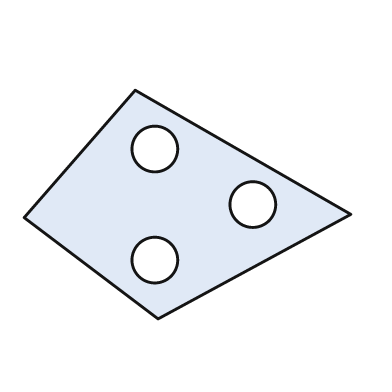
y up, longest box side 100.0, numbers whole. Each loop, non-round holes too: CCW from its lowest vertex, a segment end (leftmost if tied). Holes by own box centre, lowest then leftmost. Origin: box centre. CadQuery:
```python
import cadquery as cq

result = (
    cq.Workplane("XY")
    .moveTo(-9.0, -35.0)
    .lineTo(50.0, -3.0)
    .lineTo(-16.0, 35.0)
    .lineTo(-50.0, -4.0)
    .close()
    .moveTo(-10.0, -17.0)
    .circle(7.0)
    .moveTo(20.0, 0.0)
    .circle(7.0)
    .moveTo(-10.0, 17.0)
    .circle(7.0)
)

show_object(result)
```